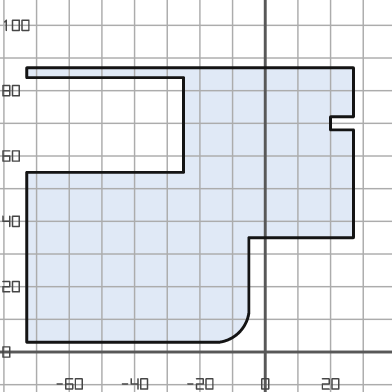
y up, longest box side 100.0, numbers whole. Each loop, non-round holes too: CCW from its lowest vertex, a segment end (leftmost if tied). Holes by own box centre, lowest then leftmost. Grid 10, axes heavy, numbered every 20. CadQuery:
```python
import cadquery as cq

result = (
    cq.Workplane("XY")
    .moveTo(-73.0, 3.0)
    .lineTo(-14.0, 3.0)
    .threePointArc((-8.0, 6.0), (-5.0, 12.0))
    .lineTo(-5.0, 35.0)
    .lineTo(27.0, 35.0)
    .lineTo(27.0, 68.0)
    .lineTo(20.0, 68.0)
    .lineTo(20.0, 72.0)
    .lineTo(27.0, 72.0)
    .lineTo(27.0, 87.0)
    .lineTo(-73.0, 87.0)
    .lineTo(-73.0, 84.0)
    .lineTo(-25.0, 84.0)
    .lineTo(-25.0, 55.0)
    .lineTo(-73.0, 55.0)
    .close()
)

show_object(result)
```